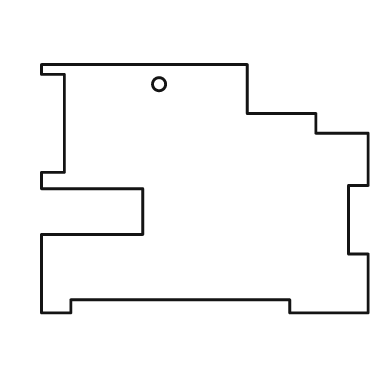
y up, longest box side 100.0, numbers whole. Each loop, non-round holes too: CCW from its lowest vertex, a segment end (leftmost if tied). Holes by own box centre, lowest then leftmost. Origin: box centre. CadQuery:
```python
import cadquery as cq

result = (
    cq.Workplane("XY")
    .moveTo(-50.0, -38.0)
    .lineTo(-41.0, -38.0)
    .lineTo(-41.0, -34.0)
    .lineTo(26.0, -34.0)
    .lineTo(26.0, -38.0)
    .lineTo(50.0, -38.0)
    .lineTo(50.0, -20.0)
    .lineTo(44.0, -20.0)
    .lineTo(44.0, 1.0)
    .lineTo(50.0, 1.0)
    .lineTo(50.0, 17.0)
    .lineTo(34.0, 17.0)
    .lineTo(34.0, 23.0)
    .lineTo(13.0, 23.0)
    .lineTo(13.0, 38.0)
    .lineTo(-50.0, 38.0)
    .lineTo(-50.0, 35.0)
    .lineTo(-43.0, 35.0)
    .lineTo(-43.0, 5.0)
    .lineTo(-50.0, 5.0)
    .lineTo(-50.0, 0.0)
    .lineTo(-19.0, 0.0)
    .lineTo(-19.0, -14.0)
    .lineTo(-50.0, -14.0)
    .close()
    .moveTo(-14.0, 32.0)
    .circle(2.0)
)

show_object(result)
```